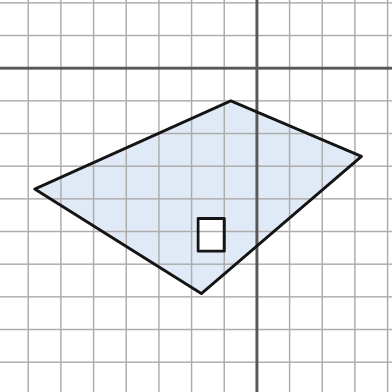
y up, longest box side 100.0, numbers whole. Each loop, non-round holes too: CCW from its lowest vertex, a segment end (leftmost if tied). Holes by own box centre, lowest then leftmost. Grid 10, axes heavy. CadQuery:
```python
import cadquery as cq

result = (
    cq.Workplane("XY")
    .moveTo(-17.0, -69.0)
    .lineTo(32.0, -27.0)
    .lineTo(-8.0, -10.0)
    .lineTo(-68.0, -37.0)
    .close()
    .moveTo(-18.0, -56.0)
    .lineTo(-10.0, -56.0)
    .lineTo(-10.0, -46.0)
    .lineTo(-18.0, -46.0)
    .close()
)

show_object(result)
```